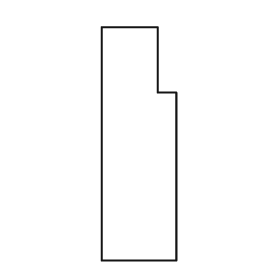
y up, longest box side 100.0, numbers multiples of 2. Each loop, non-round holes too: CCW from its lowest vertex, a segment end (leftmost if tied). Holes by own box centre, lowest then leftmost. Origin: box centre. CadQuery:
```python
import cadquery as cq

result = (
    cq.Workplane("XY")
    .moveTo(-16.0, -50.0)
    .lineTo(16.0, -50.0)
    .lineTo(16.0, 22.0)
    .lineTo(8.0, 22.0)
    .lineTo(8.0, 50.0)
    .lineTo(-16.0, 50.0)
    .close()
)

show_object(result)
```